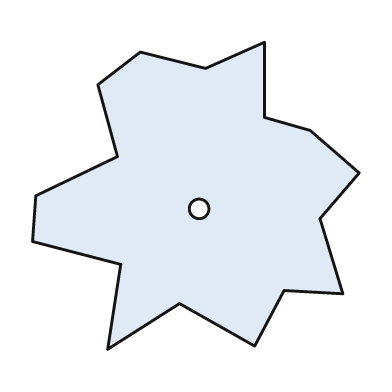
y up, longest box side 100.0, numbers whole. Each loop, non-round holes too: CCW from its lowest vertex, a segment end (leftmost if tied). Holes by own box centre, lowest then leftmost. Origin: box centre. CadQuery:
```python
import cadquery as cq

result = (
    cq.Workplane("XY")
    .moveTo(-27.0, -47.0)
    .lineTo(-5.0, -33.0)
    .lineTo(18.0, -46.0)
    .lineTo(27.0, -29.0)
    .lineTo(45.0, -30.0)
    .lineTo(38.0, -7.0)
    .lineTo(50.0, 7.0)
    .lineTo(35.0, 20.0)
    .lineTo(21.0, 24.0)
    .lineTo(21.0, 47.0)
    .lineTo(3.0, 39.0)
    .lineTo(-17.0, 44.0)
    .lineTo(-30.0, 34.0)
    .lineTo(-24.0, 12.0)
    .lineTo(-49.0, 0.0)
    .lineTo(-50.0, -14.0)
    .lineTo(-23.0, -21.0)
    .close()
    .moveTo(1.0, -4.0)
    .circle(3.0)
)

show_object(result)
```